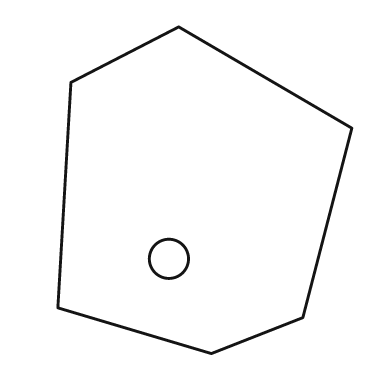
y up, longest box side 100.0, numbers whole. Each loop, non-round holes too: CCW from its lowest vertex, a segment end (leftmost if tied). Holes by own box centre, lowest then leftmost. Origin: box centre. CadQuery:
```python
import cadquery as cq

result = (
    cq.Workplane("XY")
    .moveTo(2.0, -50.0)
    .lineTo(30.0, -39.0)
    .lineTo(45.0, 19.0)
    .lineTo(-8.0, 50.0)
    .lineTo(-41.0, 33.0)
    .lineTo(-45.0, -36.0)
    .close()
    .moveTo(-11.0, -21.0)
    .circle(6.0)
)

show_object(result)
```